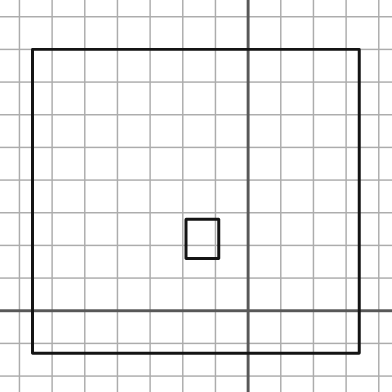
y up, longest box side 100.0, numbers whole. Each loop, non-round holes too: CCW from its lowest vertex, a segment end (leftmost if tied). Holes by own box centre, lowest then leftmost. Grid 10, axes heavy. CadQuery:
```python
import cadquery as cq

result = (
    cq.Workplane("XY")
    .moveTo(-66.0, -13.0)
    .lineTo(34.0, -13.0)
    .lineTo(34.0, 80.0)
    .lineTo(-66.0, 80.0)
    .close()
    .moveTo(-19.0, 16.0)
    .lineTo(-9.0, 16.0)
    .lineTo(-9.0, 28.0)
    .lineTo(-19.0, 28.0)
    .close()
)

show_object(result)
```